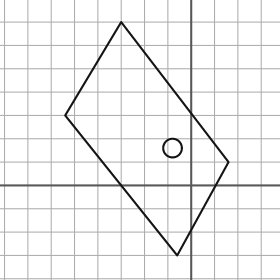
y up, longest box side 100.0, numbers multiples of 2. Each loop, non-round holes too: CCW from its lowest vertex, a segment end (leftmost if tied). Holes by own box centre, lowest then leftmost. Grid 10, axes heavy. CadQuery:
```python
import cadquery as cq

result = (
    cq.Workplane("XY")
    .moveTo(-6.0, -30.0)
    .lineTo(16.0, 10.0)
    .lineTo(-30.0, 70.0)
    .lineTo(-54.0, 30.0)
    .close()
    .moveTo(-8.0, 16.0)
    .circle(4.0)
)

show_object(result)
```